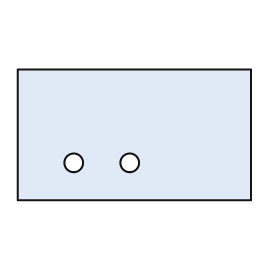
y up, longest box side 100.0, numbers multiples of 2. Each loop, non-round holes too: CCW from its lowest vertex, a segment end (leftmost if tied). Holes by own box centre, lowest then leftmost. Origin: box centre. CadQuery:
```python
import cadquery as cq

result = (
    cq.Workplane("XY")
    .moveTo(-50.0, -28.0)
    .lineTo(50.0, -28.0)
    .lineTo(50.0, 28.0)
    .lineTo(-50.0, 28.0)
    .close()
    .moveTo(-26.0, -12.0)
    .circle(4.0)
    .moveTo(-2.0, -12.0)
    .circle(4.0)
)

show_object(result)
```